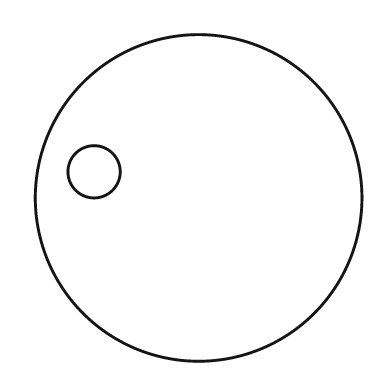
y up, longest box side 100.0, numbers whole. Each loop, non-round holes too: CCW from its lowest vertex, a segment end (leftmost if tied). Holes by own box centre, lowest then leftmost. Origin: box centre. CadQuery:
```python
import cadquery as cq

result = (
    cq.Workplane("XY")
    .moveTo(0.0, 0.0)
    .circle(50.0)
    .moveTo(-32.0, 8.0)
    .circle(8.0)
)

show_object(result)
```